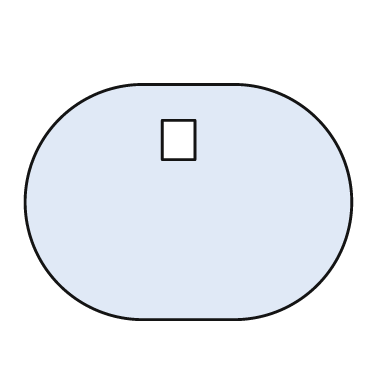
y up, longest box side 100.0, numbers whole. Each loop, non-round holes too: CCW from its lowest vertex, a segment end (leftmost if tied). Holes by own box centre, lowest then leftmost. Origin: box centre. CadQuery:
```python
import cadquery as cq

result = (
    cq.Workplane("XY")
    .moveTo(-14.0, -36.0)
    .lineTo(14.0, -36.0)
    .threePointArc((50.0, 0.0), (14.0, 36.0))
    .lineTo(-14.0, 36.0)
    .threePointArc((-50.0, 0.0), (-14.0, -36.0))
    .close()
    .moveTo(-8.0, 13.0)
    .lineTo(2.0, 13.0)
    .lineTo(2.0, 25.0)
    .lineTo(-8.0, 25.0)
    .close()
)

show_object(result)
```